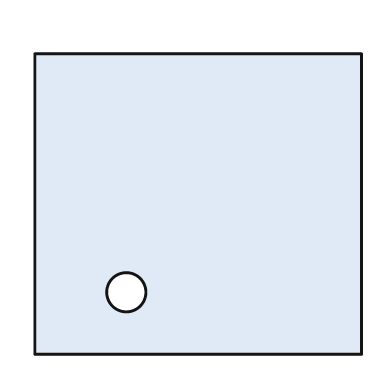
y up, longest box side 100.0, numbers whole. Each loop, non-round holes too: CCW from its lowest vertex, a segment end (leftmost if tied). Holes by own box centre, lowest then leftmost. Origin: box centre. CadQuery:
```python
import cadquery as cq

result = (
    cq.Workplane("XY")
    .moveTo(-50.0, -46.0)
    .lineTo(50.0, -46.0)
    .lineTo(50.0, 46.0)
    .lineTo(-50.0, 46.0)
    .close()
    .moveTo(-22.0, -27.0)
    .circle(6.0)
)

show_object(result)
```